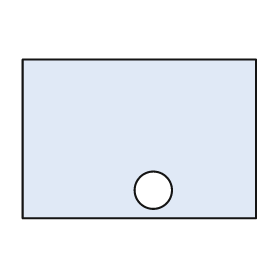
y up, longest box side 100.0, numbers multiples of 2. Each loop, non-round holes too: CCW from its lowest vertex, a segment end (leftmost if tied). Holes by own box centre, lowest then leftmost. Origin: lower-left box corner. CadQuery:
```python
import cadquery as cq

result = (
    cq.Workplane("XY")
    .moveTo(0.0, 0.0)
    .lineTo(100.0, 0.0)
    .lineTo(100.0, 68.0)
    .lineTo(0.0, 68.0)
    .close()
    .moveTo(56.0, 12.0)
    .circle(8.0)
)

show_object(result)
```